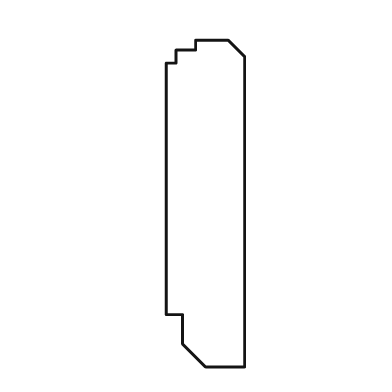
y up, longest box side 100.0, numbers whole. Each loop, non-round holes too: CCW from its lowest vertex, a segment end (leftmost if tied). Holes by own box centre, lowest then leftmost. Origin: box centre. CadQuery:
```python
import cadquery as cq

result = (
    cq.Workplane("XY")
    .moveTo(0.0, -50.0)
    .lineTo(12.0, -50.0)
    .lineTo(12.0, 45.0)
    .lineTo(7.0, 50.0)
    .lineTo(-3.0, 50.0)
    .lineTo(-3.0, 47.0)
    .lineTo(-9.0, 47.0)
    .lineTo(-9.0, 43.0)
    .lineTo(-12.0, 43.0)
    .lineTo(-12.0, -34.0)
    .lineTo(-7.0, -34.0)
    .lineTo(-7.0, -43.0)
    .close()
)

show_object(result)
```